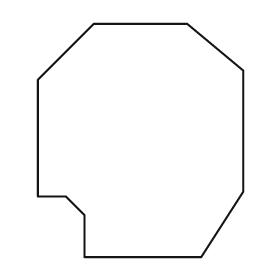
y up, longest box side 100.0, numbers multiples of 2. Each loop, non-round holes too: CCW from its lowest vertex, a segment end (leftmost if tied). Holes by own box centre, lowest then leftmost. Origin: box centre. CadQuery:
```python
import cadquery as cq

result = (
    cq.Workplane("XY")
    .moveTo(-24.0, -50.0)
    .lineTo(26.0, -50.0)
    .lineTo(44.0, -22.0)
    .lineTo(44.0, 30.0)
    .lineTo(20.0, 50.0)
    .lineTo(-20.0, 50.0)
    .lineTo(-44.0, 26.0)
    .lineTo(-44.0, -24.0)
    .lineTo(-32.0, -24.0)
    .lineTo(-24.0, -32.0)
    .close()
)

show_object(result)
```